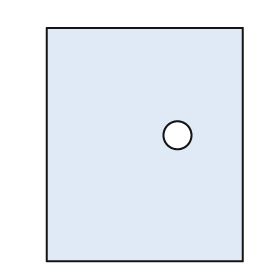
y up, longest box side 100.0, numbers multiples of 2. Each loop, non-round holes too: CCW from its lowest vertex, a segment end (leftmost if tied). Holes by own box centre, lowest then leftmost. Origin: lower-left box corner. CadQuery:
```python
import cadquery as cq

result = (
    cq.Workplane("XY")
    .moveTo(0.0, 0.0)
    .lineTo(84.0, 0.0)
    .lineTo(84.0, 100.0)
    .lineTo(0.0, 100.0)
    .close()
    .moveTo(56.0, 54.0)
    .circle(6.0)
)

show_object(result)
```